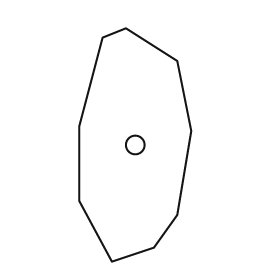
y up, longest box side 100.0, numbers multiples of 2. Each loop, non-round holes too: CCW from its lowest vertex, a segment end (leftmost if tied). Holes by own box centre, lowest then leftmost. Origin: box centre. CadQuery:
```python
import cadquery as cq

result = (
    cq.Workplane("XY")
    .moveTo(-10.0, -50.0)
    .lineTo(8.0, -44.0)
    .lineTo(18.0, -30.0)
    .lineTo(24.0, 6.0)
    .lineTo(18.0, 36.0)
    .lineTo(-4.0, 50.0)
    .lineTo(-14.0, 46.0)
    .lineTo(-24.0, 8.0)
    .lineTo(-24.0, -24.0)
    .close()
    .moveTo(0.0, 0.0)
    .circle(4.0)
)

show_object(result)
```